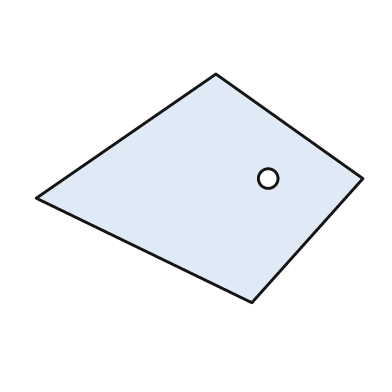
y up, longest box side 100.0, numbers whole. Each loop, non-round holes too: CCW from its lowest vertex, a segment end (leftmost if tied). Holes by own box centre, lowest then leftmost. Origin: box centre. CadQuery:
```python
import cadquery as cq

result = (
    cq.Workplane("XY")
    .moveTo(16.0, -35.0)
    .lineTo(50.0, 3.0)
    .lineTo(5.0, 35.0)
    .lineTo(-50.0, -3.0)
    .close()
    .moveTo(21.0, 3.0)
    .circle(3.0)
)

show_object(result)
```